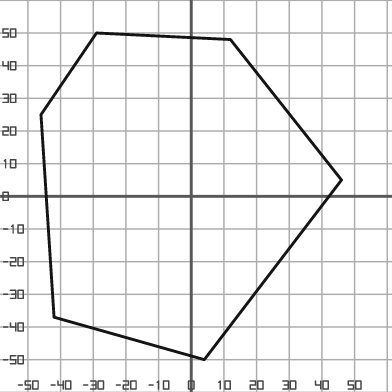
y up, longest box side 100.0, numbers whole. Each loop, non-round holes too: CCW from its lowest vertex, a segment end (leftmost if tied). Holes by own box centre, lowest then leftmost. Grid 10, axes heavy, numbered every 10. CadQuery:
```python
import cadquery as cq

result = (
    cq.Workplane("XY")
    .moveTo(4.0, -50.0)
    .lineTo(46.0, 5.0)
    .lineTo(12.0, 48.0)
    .lineTo(-29.0, 50.0)
    .lineTo(-46.0, 25.0)
    .lineTo(-42.0, -37.0)
    .close()
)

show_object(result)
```